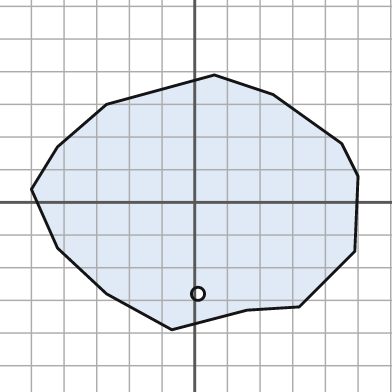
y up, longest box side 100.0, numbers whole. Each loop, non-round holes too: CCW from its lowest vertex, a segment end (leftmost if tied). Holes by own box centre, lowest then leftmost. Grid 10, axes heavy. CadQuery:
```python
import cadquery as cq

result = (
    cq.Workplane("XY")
    .moveTo(-7.0, -39.0)
    .lineTo(16.0, -33.0)
    .lineTo(32.0, -32.0)
    .lineTo(49.0, -15.0)
    .lineTo(50.0, 8.0)
    .lineTo(45.0, 18.0)
    .lineTo(24.0, 33.0)
    .lineTo(6.0, 39.0)
    .lineTo(-27.0, 30.0)
    .lineTo(-42.0, 17.0)
    .lineTo(-50.0, 4.0)
    .lineTo(-42.0, -14.0)
    .lineTo(-27.0, -28.0)
    .close()
    .moveTo(1.0, -28.0)
    .circle(2.0)
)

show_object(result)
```